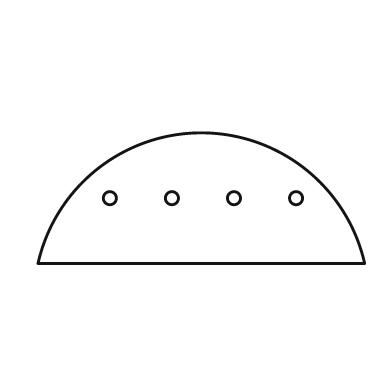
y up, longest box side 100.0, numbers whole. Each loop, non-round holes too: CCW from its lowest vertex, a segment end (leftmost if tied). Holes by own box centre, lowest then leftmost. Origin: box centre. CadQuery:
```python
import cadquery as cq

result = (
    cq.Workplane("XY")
    .moveTo(-50.0, -20.0)
    .lineTo(50.0, -20.0)
    .threePointArc((0.0, 20.0), (-50.0, -20.0))
    .close()
    .moveTo(-28.0, 0.0)
    .circle(2.0)
    .moveTo(-9.0, 0.0)
    .circle(2.0)
    .moveTo(10.0, 0.0)
    .circle(2.0)
    .moveTo(29.0, 0.0)
    .circle(2.0)
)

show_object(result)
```